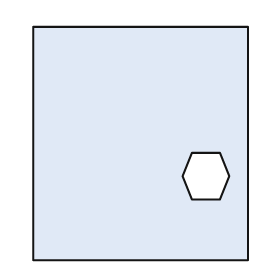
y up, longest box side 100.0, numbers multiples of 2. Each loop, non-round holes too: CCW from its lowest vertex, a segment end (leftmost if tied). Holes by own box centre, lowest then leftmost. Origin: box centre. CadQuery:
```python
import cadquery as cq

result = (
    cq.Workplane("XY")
    .moveTo(-46.0, -50.0)
    .lineTo(46.0, -50.0)
    .lineTo(46.0, 50.0)
    .lineTo(-46.0, 50.0)
    .close()
    .moveTo(22.0, -24.0)
    .lineTo(34.0, -24.0)
    .lineTo(38.0, -14.0)
    .lineTo(34.0, -4.0)
    .lineTo(22.0, -4.0)
    .lineTo(18.0, -14.0)
    .close()
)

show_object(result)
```